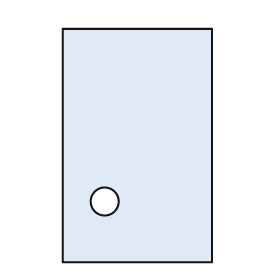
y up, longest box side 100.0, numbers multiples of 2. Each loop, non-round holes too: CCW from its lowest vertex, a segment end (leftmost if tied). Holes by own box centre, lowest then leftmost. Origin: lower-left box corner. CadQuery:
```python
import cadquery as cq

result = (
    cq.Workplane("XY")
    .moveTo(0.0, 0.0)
    .lineTo(64.0, 0.0)
    .lineTo(64.0, 100.0)
    .lineTo(0.0, 100.0)
    .close()
    .moveTo(18.0, 26.0)
    .circle(6.0)
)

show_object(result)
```